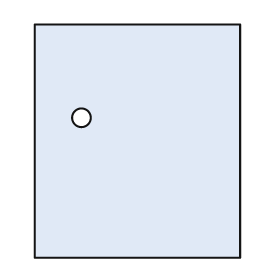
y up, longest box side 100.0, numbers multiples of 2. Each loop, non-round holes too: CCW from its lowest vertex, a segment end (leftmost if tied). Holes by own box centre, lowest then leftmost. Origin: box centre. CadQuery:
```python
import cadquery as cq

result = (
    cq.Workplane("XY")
    .moveTo(-44.0, -50.0)
    .lineTo(44.0, -50.0)
    .lineTo(44.0, 50.0)
    .lineTo(-44.0, 50.0)
    .close()
    .moveTo(-24.0, 10.0)
    .circle(4.0)
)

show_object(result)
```